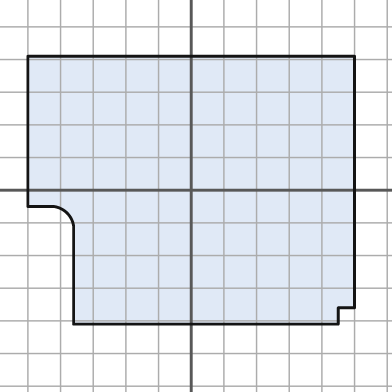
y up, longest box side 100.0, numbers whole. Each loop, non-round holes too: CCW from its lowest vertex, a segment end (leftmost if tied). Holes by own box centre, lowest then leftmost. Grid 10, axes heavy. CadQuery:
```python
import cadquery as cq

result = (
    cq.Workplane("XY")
    .moveTo(-36.0, -41.0)
    .lineTo(45.0, -41.0)
    .lineTo(45.0, -36.0)
    .lineTo(50.0, -36.0)
    .lineTo(50.0, 41.0)
    .lineTo(-50.0, 41.0)
    .lineTo(-50.0, -5.0)
    .lineTo(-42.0, -5.0)
    .threePointArc((-38.0, -7.0), (-36.0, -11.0))
    .close()
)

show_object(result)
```